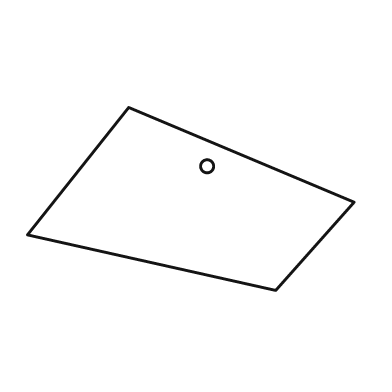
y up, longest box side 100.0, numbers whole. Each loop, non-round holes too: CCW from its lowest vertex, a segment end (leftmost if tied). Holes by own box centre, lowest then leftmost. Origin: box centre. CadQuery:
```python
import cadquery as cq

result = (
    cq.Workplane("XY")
    .moveTo(26.0, -28.0)
    .lineTo(50.0, -1.0)
    .lineTo(-19.0, 28.0)
    .lineTo(-50.0, -11.0)
    .close()
    .moveTo(5.0, 10.0)
    .circle(2.0)
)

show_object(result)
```